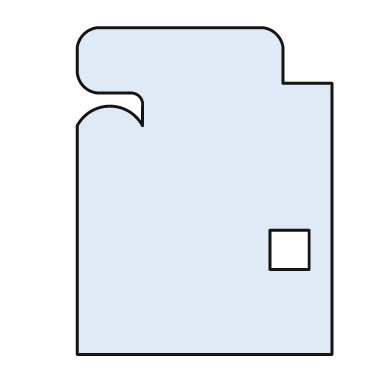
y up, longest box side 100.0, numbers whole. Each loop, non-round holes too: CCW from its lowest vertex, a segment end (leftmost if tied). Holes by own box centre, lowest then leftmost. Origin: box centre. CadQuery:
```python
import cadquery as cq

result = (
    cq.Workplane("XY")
    .moveTo(-39.0, -50.0)
    .lineTo(39.0, -50.0)
    .lineTo(39.0, 33.0)
    .lineTo(24.0, 33.0)
    .lineTo(24.0, 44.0)
    .threePointArc((22.0, 48.0), (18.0, 50.0))
    .lineTo(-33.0, 50.0)
    .threePointArc((-37.0, 48.0), (-39.0, 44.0))
    .lineTo(-39.0, 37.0)
    .threePointArc((-37.0, 32.0), (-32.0, 30.0))
    .lineTo(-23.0, 30.0)
    .threePointArc((-20.0, 29.0), (-19.0, 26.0))
    .lineTo(-19.0, 20.0)
    .threePointArc((-29.0, 26.0), (-39.0, 20.0))
    .close()
    .moveTo(20.0, -24.0)
    .lineTo(32.0, -24.0)
    .lineTo(32.0, -12.0)
    .lineTo(20.0, -12.0)
    .close()
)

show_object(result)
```